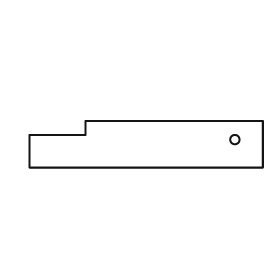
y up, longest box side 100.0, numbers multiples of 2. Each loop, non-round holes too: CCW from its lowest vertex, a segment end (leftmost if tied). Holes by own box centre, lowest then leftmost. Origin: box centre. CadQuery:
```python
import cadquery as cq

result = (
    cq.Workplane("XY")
    .moveTo(-50.0, -10.0)
    .lineTo(50.0, -10.0)
    .lineTo(50.0, 10.0)
    .lineTo(-26.0, 10.0)
    .lineTo(-26.0, 4.0)
    .lineTo(-50.0, 4.0)
    .close()
    .moveTo(38.0, 2.0)
    .circle(2.0)
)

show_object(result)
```